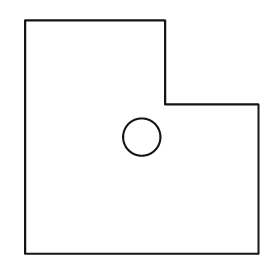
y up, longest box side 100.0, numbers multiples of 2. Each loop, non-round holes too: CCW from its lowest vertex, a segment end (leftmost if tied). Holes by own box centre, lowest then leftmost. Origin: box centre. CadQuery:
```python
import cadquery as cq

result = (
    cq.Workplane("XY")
    .moveTo(-50.0, -50.0)
    .lineTo(50.0, -50.0)
    .lineTo(50.0, 14.0)
    .lineTo(10.0, 14.0)
    .lineTo(10.0, 50.0)
    .lineTo(-50.0, 50.0)
    .close()
    .moveTo(0.0, 0.0)
    .circle(8.0)
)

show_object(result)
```